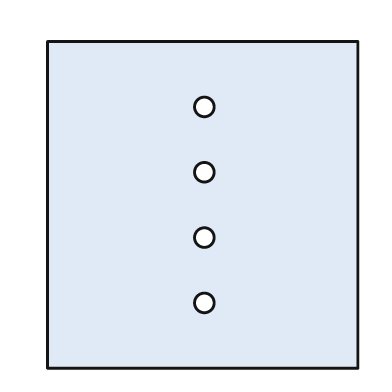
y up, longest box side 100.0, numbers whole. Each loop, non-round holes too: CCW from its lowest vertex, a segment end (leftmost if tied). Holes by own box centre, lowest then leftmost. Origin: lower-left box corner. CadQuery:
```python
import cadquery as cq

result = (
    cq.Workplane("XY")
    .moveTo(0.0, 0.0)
    .lineTo(95.0, 0.0)
    .lineTo(95.0, 100.0)
    .lineTo(0.0, 100.0)
    .close()
    .moveTo(48.0, 20.0)
    .circle(3.0)
    .moveTo(48.0, 40.0)
    .circle(3.0)
    .moveTo(48.0, 60.0)
    .circle(3.0)
    .moveTo(48.0, 80.0)
    .circle(3.0)
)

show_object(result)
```